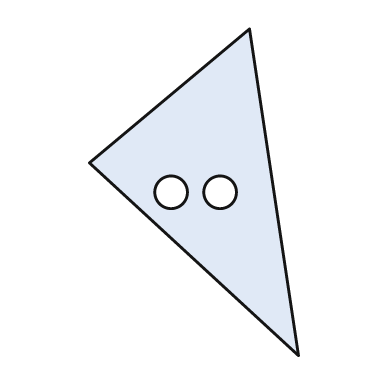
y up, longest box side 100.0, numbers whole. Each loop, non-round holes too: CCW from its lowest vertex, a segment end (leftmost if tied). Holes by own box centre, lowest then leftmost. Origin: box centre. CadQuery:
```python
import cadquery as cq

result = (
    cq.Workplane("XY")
    .moveTo(32.0, -50.0)
    .lineTo(17.0, 50.0)
    .lineTo(-32.0, 9.0)
    .close()
    .moveTo(-7.0, 0.0)
    .circle(5.0)
    .moveTo(8.0, 0.0)
    .circle(5.0)
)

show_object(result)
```